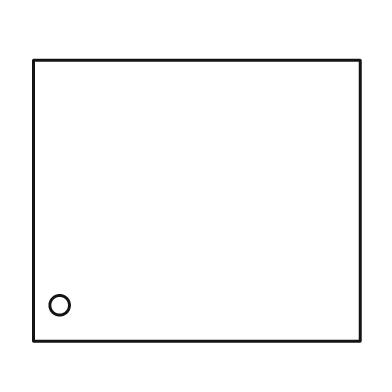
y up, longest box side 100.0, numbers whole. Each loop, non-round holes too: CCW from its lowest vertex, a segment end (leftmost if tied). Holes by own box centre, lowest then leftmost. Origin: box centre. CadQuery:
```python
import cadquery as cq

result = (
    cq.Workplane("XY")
    .moveTo(-50.0, -43.0)
    .lineTo(50.0, -43.0)
    .lineTo(50.0, 43.0)
    .lineTo(-50.0, 43.0)
    .close()
    .moveTo(-42.0, -32.0)
    .circle(3.0)
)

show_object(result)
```